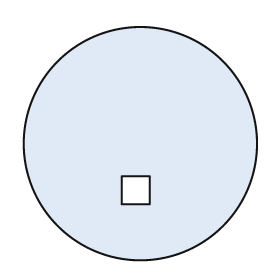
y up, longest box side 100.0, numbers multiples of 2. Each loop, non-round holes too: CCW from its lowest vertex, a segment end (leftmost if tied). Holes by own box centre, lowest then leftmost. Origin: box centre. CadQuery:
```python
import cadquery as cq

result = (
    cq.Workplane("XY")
    .moveTo(0.0, 0.0)
    .circle(50.0)
    .moveTo(-8.0, -26.0)
    .lineTo(4.0, -26.0)
    .lineTo(4.0, -14.0)
    .lineTo(-8.0, -14.0)
    .close()
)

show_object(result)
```